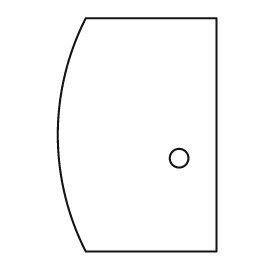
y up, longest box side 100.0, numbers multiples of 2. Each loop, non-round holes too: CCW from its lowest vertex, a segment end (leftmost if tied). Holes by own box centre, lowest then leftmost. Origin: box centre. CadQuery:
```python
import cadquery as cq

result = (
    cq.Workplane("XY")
    .moveTo(-22.0, -50.0)
    .lineTo(34.0, -50.0)
    .lineTo(34.0, 50.0)
    .lineTo(-22.0, 50.0)
    .threePointArc((-34.0, 0.0), (-22.0, -50.0))
    .close()
    .moveTo(18.0, -10.0)
    .circle(4.0)
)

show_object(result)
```